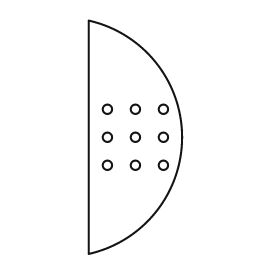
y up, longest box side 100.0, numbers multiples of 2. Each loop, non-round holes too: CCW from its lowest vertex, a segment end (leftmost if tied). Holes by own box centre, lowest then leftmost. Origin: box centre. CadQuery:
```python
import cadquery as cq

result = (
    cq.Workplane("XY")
    .moveTo(-20.0, -50.0)
    .threePointArc((20.0, 0.0), (-20.0, 50.0))
    .close()
    .moveTo(-12.0, -12.0)
    .circle(2.0)
    .moveTo(0.0, -12.0)
    .circle(2.0)
    .moveTo(12.0, -12.0)
    .circle(2.0)
    .moveTo(-12.0, 0.0)
    .circle(2.0)
    .moveTo(0.0, 0.0)
    .circle(2.0)
    .moveTo(12.0, 0.0)
    .circle(2.0)
    .moveTo(-12.0, 12.0)
    .circle(2.0)
    .moveTo(0.0, 12.0)
    .circle(2.0)
    .moveTo(12.0, 12.0)
    .circle(2.0)
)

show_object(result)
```